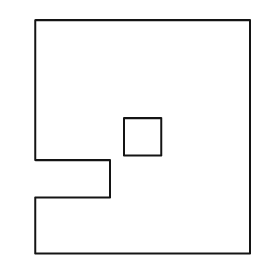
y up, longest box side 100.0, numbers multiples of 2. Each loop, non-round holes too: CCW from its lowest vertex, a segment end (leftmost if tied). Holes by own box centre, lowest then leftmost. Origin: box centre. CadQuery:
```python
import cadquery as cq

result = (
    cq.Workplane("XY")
    .moveTo(-46.0, -50.0)
    .lineTo(46.0, -50.0)
    .lineTo(46.0, 50.0)
    .lineTo(-46.0, 50.0)
    .lineTo(-46.0, -10.0)
    .lineTo(-14.0, -10.0)
    .lineTo(-14.0, -26.0)
    .lineTo(-46.0, -26.0)
    .close()
    .moveTo(-8.0, -8.0)
    .lineTo(8.0, -8.0)
    .lineTo(8.0, 8.0)
    .lineTo(-8.0, 8.0)
    .close()
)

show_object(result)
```